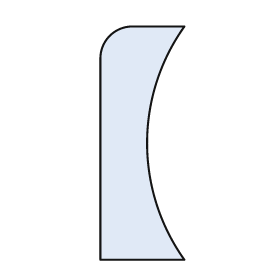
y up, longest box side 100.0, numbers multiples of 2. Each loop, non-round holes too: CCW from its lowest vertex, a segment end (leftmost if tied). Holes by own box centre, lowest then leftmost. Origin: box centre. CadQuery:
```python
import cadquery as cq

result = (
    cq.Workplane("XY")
    .moveTo(-18.0, -50.0)
    .lineTo(18.0, -50.0)
    .threePointArc((2.0, 0.0), (18.0, 50.0))
    .lineTo(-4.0, 50.0)
    .threePointArc((-14.0, 46.0), (-18.0, 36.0))
    .close()
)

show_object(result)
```